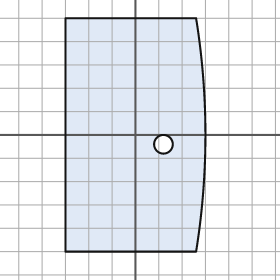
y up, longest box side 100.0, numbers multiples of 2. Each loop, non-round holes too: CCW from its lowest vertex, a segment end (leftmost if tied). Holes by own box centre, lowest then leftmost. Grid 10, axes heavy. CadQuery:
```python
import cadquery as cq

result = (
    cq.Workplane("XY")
    .moveTo(-30.0, -50.0)
    .lineTo(26.0, -50.0)
    .threePointArc((30.0, 0.0), (26.0, 50.0))
    .lineTo(-30.0, 50.0)
    .close()
    .moveTo(12.0, -4.0)
    .circle(4.0)
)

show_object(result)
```